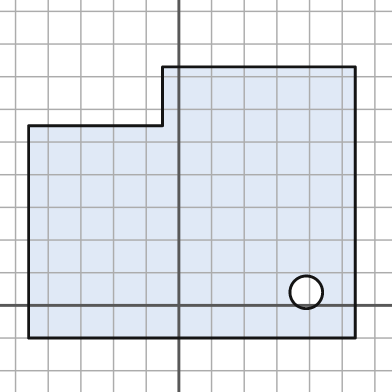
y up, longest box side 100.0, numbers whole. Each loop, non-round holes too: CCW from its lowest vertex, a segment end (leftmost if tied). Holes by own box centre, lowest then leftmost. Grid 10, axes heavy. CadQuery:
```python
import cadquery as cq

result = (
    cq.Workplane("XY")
    .moveTo(-46.0, -10.0)
    .lineTo(54.0, -10.0)
    .lineTo(54.0, 73.0)
    .lineTo(-5.0, 73.0)
    .lineTo(-5.0, 55.0)
    .lineTo(-46.0, 55.0)
    .close()
    .moveTo(39.0, 4.0)
    .circle(5.0)
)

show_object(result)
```